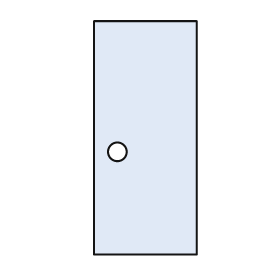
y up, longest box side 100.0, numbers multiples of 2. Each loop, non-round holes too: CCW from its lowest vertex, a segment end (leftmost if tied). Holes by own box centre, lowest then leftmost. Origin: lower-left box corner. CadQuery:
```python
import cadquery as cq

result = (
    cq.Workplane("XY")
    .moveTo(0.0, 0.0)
    .lineTo(44.0, 0.0)
    .lineTo(44.0, 100.0)
    .lineTo(0.0, 100.0)
    .close()
    .moveTo(10.0, 44.0)
    .circle(4.0)
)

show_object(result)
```